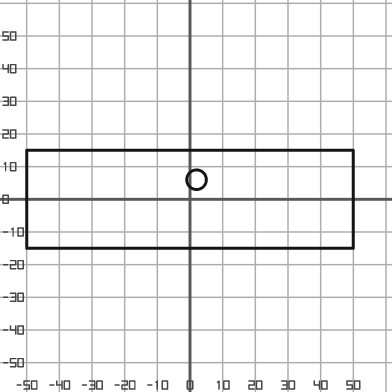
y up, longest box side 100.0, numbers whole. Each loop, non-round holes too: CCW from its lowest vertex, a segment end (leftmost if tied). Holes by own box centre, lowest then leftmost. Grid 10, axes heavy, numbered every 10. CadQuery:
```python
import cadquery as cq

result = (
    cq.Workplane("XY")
    .moveTo(-50.0, -15.0)
    .lineTo(50.0, -15.0)
    .lineTo(50.0, 15.0)
    .lineTo(-50.0, 15.0)
    .close()
    .moveTo(2.0, 6.0)
    .circle(3.0)
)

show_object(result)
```